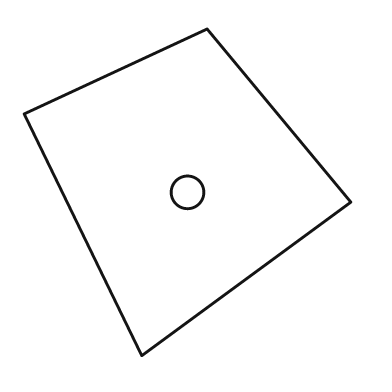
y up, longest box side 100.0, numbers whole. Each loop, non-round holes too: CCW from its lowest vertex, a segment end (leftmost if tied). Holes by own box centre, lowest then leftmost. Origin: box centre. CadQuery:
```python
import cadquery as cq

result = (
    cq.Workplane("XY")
    .moveTo(-14.0, -50.0)
    .lineTo(50.0, -3.0)
    .lineTo(6.0, 50.0)
    .lineTo(-50.0, 24.0)
    .close()
    .moveTo(0.0, 0.0)
    .circle(5.0)
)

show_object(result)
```